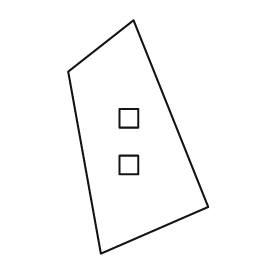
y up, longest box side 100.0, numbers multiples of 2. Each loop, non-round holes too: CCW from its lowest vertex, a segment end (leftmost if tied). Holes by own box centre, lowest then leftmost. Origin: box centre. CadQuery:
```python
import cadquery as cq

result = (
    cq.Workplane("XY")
    .moveTo(-16.0, -50.0)
    .lineTo(30.0, -30.0)
    .lineTo(-2.0, 50.0)
    .lineTo(-30.0, 28.0)
    .close()
    .moveTo(-8.0, -16.0)
    .lineTo(0.0, -16.0)
    .lineTo(0.0, -8.0)
    .lineTo(-8.0, -8.0)
    .close()
    .moveTo(-8.0, 4.0)
    .lineTo(0.0, 4.0)
    .lineTo(0.0, 12.0)
    .lineTo(-8.0, 12.0)
    .close()
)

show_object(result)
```